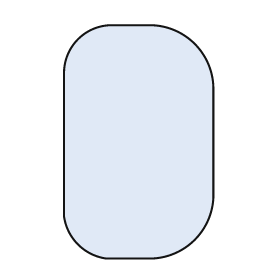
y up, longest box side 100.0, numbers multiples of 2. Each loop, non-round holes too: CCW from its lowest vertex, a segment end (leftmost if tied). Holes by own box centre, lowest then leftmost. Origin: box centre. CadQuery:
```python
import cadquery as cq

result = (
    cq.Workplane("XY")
    .moveTo(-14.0, -50.0)
    .lineTo(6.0, -50.0)
    .threePointArc((24.0, -42.0), (32.0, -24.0))
    .lineTo(32.0, 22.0)
    .threePointArc((24.0, 42.0), (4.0, 50.0))
    .lineTo(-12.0, 50.0)
    .threePointArc((-26.0, 44.0), (-32.0, 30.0))
    .lineTo(-32.0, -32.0)
    .threePointArc((-26.0, -44.0), (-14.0, -50.0))
    .close()
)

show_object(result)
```